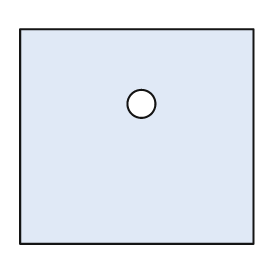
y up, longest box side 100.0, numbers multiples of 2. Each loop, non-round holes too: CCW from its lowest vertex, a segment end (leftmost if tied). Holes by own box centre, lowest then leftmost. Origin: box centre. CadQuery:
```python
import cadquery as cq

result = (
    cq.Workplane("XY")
    .moveTo(-50.0, -46.0)
    .lineTo(50.0, -46.0)
    .lineTo(50.0, 46.0)
    .lineTo(-50.0, 46.0)
    .close()
    .moveTo(2.0, 14.0)
    .circle(6.0)
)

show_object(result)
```